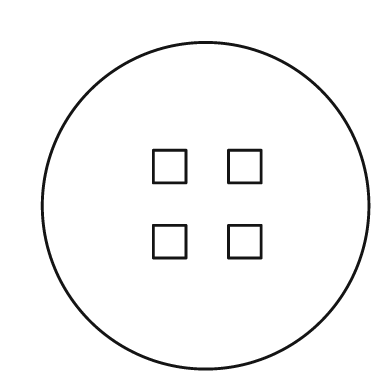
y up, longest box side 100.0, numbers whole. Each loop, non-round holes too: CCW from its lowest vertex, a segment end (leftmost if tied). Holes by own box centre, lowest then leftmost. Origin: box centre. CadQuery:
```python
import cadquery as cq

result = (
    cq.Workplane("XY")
    .moveTo(0.0, 0.0)
    .circle(50.0)
    .moveTo(-16.0, -16.0)
    .lineTo(-6.0, -16.0)
    .lineTo(-6.0, -6.0)
    .lineTo(-16.0, -6.0)
    .close()
    .moveTo(7.0, -16.0)
    .lineTo(17.0, -16.0)
    .lineTo(17.0, -6.0)
    .lineTo(7.0, -6.0)
    .close()
    .moveTo(-16.0, 7.0)
    .lineTo(-6.0, 7.0)
    .lineTo(-6.0, 17.0)
    .lineTo(-16.0, 17.0)
    .close()
    .moveTo(7.0, 7.0)
    .lineTo(17.0, 7.0)
    .lineTo(17.0, 17.0)
    .lineTo(7.0, 17.0)
    .close()
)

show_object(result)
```